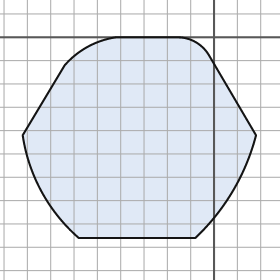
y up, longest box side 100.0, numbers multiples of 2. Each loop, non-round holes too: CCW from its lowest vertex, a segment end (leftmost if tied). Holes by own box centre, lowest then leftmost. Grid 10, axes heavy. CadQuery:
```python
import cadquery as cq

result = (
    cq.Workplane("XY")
    .moveTo(-58.0, -86.0)
    .lineTo(-8.0, -86.0)
    .threePointArc((8.0, -66.0), (18.0, -42.0))
    .lineTo(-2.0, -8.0)
    .threePointArc((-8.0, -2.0), (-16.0, 0.0))
    .lineTo(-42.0, 0.0)
    .threePointArc((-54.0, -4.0), (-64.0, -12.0))
    .lineTo(-82.0, -42.0)
    .threePointArc((-74.0, -66.0), (-58.0, -86.0))
    .close()
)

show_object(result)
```